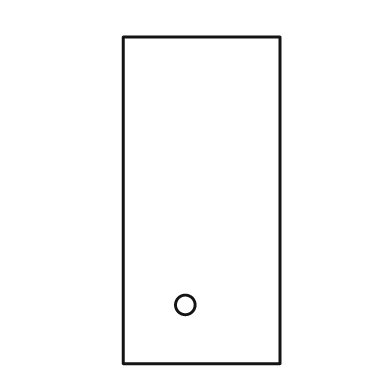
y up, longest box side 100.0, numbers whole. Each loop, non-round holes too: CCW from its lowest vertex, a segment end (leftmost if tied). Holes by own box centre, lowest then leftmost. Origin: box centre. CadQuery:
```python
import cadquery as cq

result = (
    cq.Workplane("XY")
    .moveTo(-24.0, -50.0)
    .lineTo(24.0, -50.0)
    .lineTo(24.0, 50.0)
    .lineTo(-24.0, 50.0)
    .close()
    .moveTo(-5.0, -32.0)
    .circle(3.0)
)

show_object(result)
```